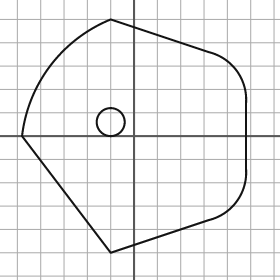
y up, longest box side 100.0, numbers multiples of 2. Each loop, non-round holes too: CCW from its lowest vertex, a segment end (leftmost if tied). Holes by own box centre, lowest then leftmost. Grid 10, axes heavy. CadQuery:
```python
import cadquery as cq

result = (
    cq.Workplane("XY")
    .moveTo(-10.0, -50.0)
    .lineTo(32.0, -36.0)
    .threePointArc((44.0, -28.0), (48.0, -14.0))
    .lineTo(48.0, 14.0)
    .threePointArc((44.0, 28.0), (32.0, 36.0))
    .lineTo(-10.0, 50.0)
    .threePointArc((-36.0, 30.0), (-48.0, 0.0))
    .close()
    .moveTo(-10.0, 6.0)
    .circle(6.0)
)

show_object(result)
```